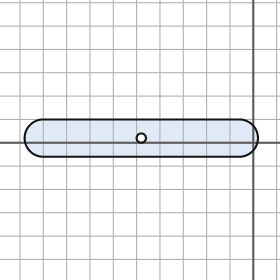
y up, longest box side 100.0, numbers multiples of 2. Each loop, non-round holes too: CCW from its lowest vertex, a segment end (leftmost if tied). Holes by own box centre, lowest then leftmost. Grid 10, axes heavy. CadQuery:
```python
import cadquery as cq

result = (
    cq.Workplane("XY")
    .moveTo(-90.0, -6.0)
    .lineTo(-6.0, -6.0)
    .threePointArc((2.0, 2.0), (-6.0, 10.0))
    .lineTo(-90.0, 10.0)
    .threePointArc((-98.0, 2.0), (-90.0, -6.0))
    .close()
    .moveTo(-48.0, 2.0)
    .circle(2.0)
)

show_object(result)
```